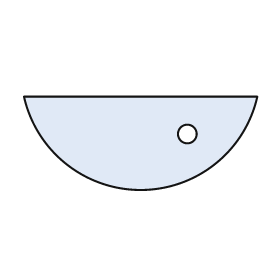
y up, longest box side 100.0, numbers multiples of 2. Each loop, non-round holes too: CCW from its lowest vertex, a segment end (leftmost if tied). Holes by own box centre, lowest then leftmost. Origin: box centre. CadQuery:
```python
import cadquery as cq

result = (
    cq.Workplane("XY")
    .moveTo(-50.0, 20.0)
    .threePointArc((0.0, -20.0), (50.0, 20.0))
    .close()
    .moveTo(20.0, 4.0)
    .circle(4.0)
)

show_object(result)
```